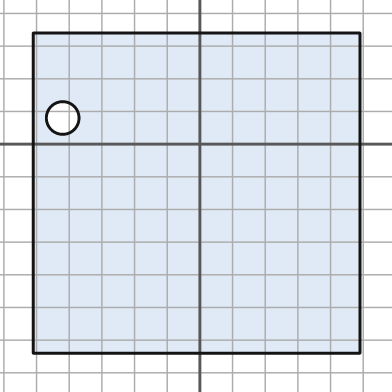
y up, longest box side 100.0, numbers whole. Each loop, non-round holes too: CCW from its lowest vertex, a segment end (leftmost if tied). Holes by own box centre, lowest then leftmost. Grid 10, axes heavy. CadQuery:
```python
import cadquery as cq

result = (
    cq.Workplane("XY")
    .moveTo(-51.0, -64.0)
    .lineTo(49.0, -64.0)
    .lineTo(49.0, 34.0)
    .lineTo(-51.0, 34.0)
    .close()
    .moveTo(-42.0, 8.0)
    .circle(5.0)
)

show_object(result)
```